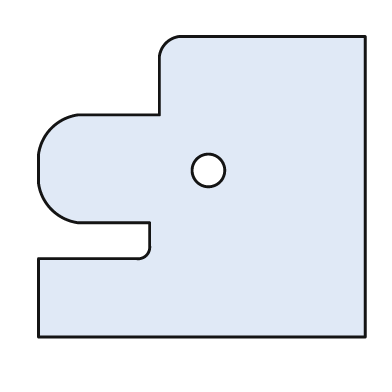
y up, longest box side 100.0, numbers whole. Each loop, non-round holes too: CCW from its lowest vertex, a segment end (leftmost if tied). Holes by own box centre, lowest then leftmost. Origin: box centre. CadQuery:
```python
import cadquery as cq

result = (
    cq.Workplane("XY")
    .moveTo(-50.0, -46.0)
    .lineTo(50.0, -46.0)
    .lineTo(50.0, 46.0)
    .lineTo(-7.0, 46.0)
    .threePointArc((-11.0, 44.0), (-13.0, 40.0))
    .lineTo(-13.0, 22.0)
    .lineTo(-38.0, 22.0)
    .threePointArc((-46.0, 18.0), (-50.0, 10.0))
    .lineTo(-50.0, 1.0)
    .threePointArc((-46.0, -7.0), (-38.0, -11.0))
    .lineTo(-16.0, -11.0)
    .lineTo(-16.0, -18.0)
    .threePointArc((-17.0, -21.0), (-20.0, -22.0))
    .lineTo(-50.0, -22.0)
    .close()
    .moveTo(2.0, 5.0)
    .circle(5.0)
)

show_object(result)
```